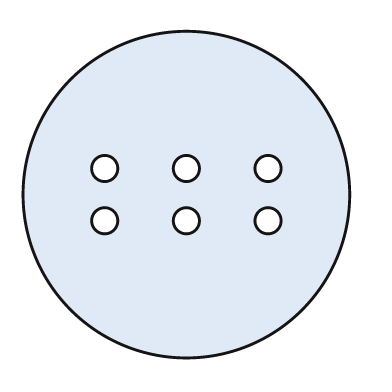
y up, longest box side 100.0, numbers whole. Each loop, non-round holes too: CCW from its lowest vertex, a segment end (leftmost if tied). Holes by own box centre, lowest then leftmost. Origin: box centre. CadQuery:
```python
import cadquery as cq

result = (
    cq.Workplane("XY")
    .moveTo(0.0, 0.0)
    .circle(50.0)
    .moveTo(-25.0, -8.0)
    .circle(4.0)
    .moveTo(0.0, -8.0)
    .circle(4.0)
    .moveTo(25.0, -8.0)
    .circle(4.0)
    .moveTo(-25.0, 8.0)
    .circle(4.0)
    .moveTo(0.0, 8.0)
    .circle(4.0)
    .moveTo(25.0, 8.0)
    .circle(4.0)
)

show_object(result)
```